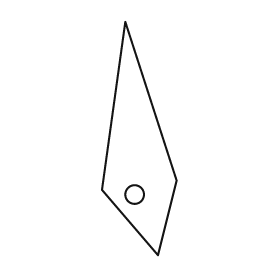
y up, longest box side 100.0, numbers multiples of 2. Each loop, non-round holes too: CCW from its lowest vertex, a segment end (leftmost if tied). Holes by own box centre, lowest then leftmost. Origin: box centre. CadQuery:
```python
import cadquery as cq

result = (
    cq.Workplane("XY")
    .moveTo(8.0, -50.0)
    .lineTo(16.0, -18.0)
    .lineTo(-6.0, 50.0)
    .lineTo(-16.0, -22.0)
    .close()
    .moveTo(-2.0, -24.0)
    .circle(4.0)
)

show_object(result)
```